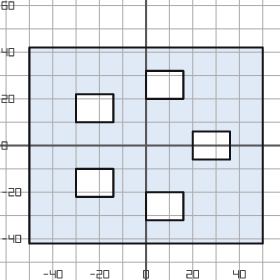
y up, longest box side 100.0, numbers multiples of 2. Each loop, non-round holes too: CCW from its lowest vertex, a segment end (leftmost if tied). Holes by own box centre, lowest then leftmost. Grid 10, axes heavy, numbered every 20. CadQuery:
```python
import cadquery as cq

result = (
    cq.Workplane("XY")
    .moveTo(-50.0, -42.0)
    .lineTo(50.0, -42.0)
    .lineTo(50.0, 42.0)
    .lineTo(-50.0, 42.0)
    .close()
    .moveTo(0.0, -32.0)
    .lineTo(16.0, -32.0)
    .lineTo(16.0, -20.0)
    .lineTo(0.0, -20.0)
    .close()
    .moveTo(-30.0, -22.0)
    .lineTo(-14.0, -22.0)
    .lineTo(-14.0, -10.0)
    .lineTo(-30.0, -10.0)
    .close()
    .moveTo(20.0, -6.0)
    .lineTo(36.0, -6.0)
    .lineTo(36.0, 6.0)
    .lineTo(20.0, 6.0)
    .close()
    .moveTo(-30.0, 10.0)
    .lineTo(-14.0, 10.0)
    .lineTo(-14.0, 22.0)
    .lineTo(-30.0, 22.0)
    .close()
    .moveTo(0.0, 20.0)
    .lineTo(16.0, 20.0)
    .lineTo(16.0, 32.0)
    .lineTo(0.0, 32.0)
    .close()
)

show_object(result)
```